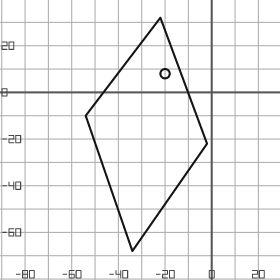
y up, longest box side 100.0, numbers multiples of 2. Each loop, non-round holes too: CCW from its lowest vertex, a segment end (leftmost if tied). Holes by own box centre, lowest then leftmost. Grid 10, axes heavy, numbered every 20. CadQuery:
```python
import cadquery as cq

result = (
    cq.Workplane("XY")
    .moveTo(-34.0, -68.0)
    .lineTo(-2.0, -22.0)
    .lineTo(-22.0, 32.0)
    .lineTo(-54.0, -10.0)
    .close()
    .moveTo(-20.0, 8.0)
    .circle(2.0)
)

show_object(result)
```